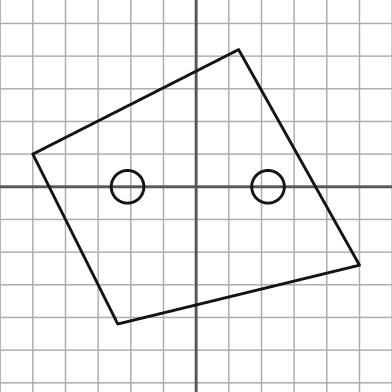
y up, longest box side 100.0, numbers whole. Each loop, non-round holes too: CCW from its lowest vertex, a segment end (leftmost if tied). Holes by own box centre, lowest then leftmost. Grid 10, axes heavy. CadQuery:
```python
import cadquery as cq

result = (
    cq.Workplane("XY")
    .moveTo(-24.0, -42.0)
    .lineTo(50.0, -24.0)
    .lineTo(13.0, 42.0)
    .lineTo(-50.0, 10.0)
    .close()
    .moveTo(-21.0, 0.0)
    .circle(5.0)
    .moveTo(22.0, 0.0)
    .circle(5.0)
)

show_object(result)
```